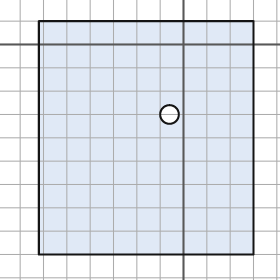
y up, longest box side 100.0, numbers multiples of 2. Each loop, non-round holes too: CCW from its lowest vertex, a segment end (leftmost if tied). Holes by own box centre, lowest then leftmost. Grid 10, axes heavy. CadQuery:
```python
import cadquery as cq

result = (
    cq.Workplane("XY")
    .moveTo(-62.0, -90.0)
    .lineTo(30.0, -90.0)
    .lineTo(30.0, 10.0)
    .lineTo(-62.0, 10.0)
    .close()
    .moveTo(-6.0, -30.0)
    .circle(4.0)
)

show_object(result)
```